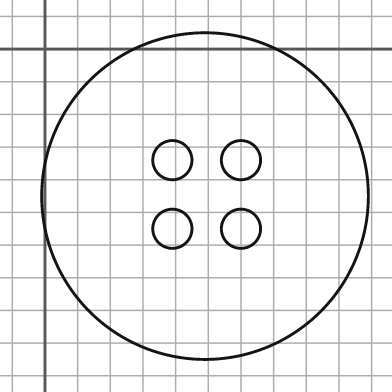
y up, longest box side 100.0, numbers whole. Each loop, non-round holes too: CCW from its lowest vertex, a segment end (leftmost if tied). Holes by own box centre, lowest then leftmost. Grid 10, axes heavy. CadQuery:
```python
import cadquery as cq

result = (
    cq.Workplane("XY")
    .moveTo(49.0, -45.0)
    .circle(50.0)
    .moveTo(39.0, -55.0)
    .circle(6.0)
    .moveTo(60.0, -55.0)
    .circle(6.0)
    .moveTo(39.0, -34.0)
    .circle(6.0)
    .moveTo(60.0, -34.0)
    .circle(6.0)
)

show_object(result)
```